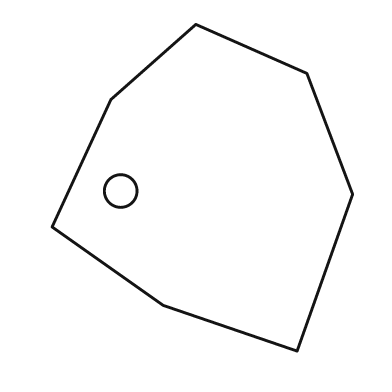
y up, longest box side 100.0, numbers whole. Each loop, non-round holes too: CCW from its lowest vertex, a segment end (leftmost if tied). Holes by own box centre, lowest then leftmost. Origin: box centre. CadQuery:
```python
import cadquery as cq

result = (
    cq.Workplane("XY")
    .moveTo(29.0, -50.0)
    .lineTo(46.0, -2.0)
    .lineTo(32.0, 35.0)
    .lineTo(-2.0, 50.0)
    .lineTo(-28.0, 27.0)
    .lineTo(-46.0, -12.0)
    .lineTo(-12.0, -36.0)
    .close()
    .moveTo(-25.0, -1.0)
    .circle(5.0)
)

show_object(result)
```